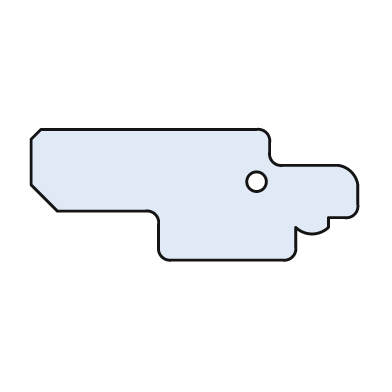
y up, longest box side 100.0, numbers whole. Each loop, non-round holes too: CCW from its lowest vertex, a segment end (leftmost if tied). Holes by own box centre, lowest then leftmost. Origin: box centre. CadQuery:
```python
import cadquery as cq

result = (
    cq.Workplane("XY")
    .moveTo(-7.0, -20.0)
    .lineTo(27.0, -20.0)
    .threePointArc((30.0, -19.0), (31.0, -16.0))
    .lineTo(31.0, -10.0)
    .threePointArc((36.0, -12.0), (41.0, -10.0))
    .lineTo(41.0, -7.0)
    .lineTo(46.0, -7.0)
    .threePointArc((49.0, -6.0), (50.0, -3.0))
    .lineTo(50.0, 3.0)
    .threePointArc((48.0, 7.0), (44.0, 9.0))
    .lineTo(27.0, 9.0)
    .threePointArc((24.0, 10.0), (23.0, 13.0))
    .lineTo(23.0, 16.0)
    .threePointArc((22.0, 19.0), (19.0, 20.0))
    .lineTo(-47.0, 20.0)
    .lineTo(-50.0, 17.0)
    .lineTo(-50.0, 3.0)
    .lineTo(-42.0, -5.0)
    .lineTo(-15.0, -5.0)
    .threePointArc((-12.0, -6.0), (-11.0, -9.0))
    .lineTo(-11.0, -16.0)
    .threePointArc((-10.0, -19.0), (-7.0, -20.0))
    .close()
    .moveTo(19.0, 4.0)
    .circle(3.0)
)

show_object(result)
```